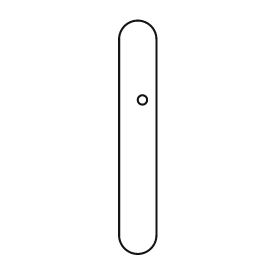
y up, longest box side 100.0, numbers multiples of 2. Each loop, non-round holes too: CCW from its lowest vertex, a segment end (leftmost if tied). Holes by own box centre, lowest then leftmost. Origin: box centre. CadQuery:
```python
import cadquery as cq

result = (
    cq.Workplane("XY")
    .moveTo(-8.0, -42.0)
    .threePointArc((0.0, -50.0), (8.0, -42.0))
    .lineTo(8.0, 42.0)
    .threePointArc((0.0, 50.0), (-8.0, 42.0))
    .close()
    .moveTo(2.0, 16.0)
    .circle(2.0)
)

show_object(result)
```